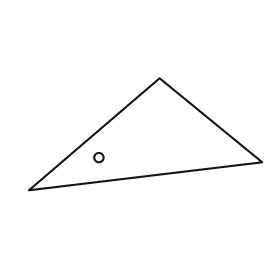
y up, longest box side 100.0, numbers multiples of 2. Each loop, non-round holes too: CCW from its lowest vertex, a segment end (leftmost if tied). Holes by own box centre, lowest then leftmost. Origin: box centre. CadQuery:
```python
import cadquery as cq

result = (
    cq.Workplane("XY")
    .moveTo(-50.0, -24.0)
    .lineTo(50.0, -12.0)
    .lineTo(6.0, 24.0)
    .close()
    .moveTo(-20.0, -10.0)
    .circle(2.0)
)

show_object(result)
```